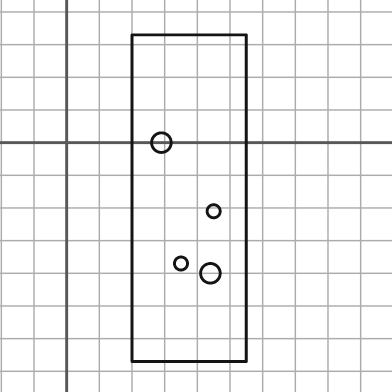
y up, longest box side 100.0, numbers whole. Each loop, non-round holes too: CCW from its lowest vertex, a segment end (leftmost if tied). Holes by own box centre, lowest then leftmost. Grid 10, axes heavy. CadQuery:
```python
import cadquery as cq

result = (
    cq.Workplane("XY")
    .moveTo(20.0, -67.0)
    .lineTo(55.0, -67.0)
    .lineTo(55.0, 33.0)
    .lineTo(20.0, 33.0)
    .close()
    .moveTo(44.0, -40.0)
    .circle(3.0)
    .moveTo(35.0, -37.0)
    .circle(2.0)
    .moveTo(45.0, -21.0)
    .circle(2.0)
    .moveTo(29.0, 0.0)
    .circle(3.0)
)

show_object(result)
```